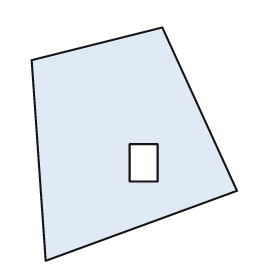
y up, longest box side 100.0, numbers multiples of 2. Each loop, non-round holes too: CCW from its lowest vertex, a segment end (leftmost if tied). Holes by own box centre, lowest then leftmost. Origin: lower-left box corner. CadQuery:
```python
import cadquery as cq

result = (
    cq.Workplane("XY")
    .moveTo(6.0, 0.0)
    .lineTo(88.0, 30.0)
    .lineTo(56.0, 100.0)
    .lineTo(0.0, 86.0)
    .close()
    .moveTo(42.0, 34.0)
    .lineTo(54.0, 34.0)
    .lineTo(54.0, 50.0)
    .lineTo(42.0, 50.0)
    .close()
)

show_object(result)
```